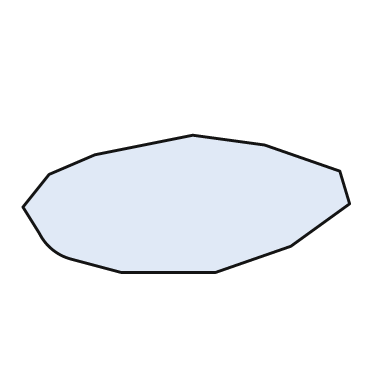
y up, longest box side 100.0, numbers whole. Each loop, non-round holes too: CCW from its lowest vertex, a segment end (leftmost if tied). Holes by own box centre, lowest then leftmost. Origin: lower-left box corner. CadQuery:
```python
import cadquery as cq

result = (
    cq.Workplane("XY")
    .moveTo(30.0, 0.0)
    .lineTo(59.0, 0.0)
    .lineTo(82.0, 8.0)
    .lineTo(100.0, 21.0)
    .lineTo(97.0, 31.0)
    .lineTo(74.0, 39.0)
    .lineTo(52.0, 42.0)
    .lineTo(22.0, 36.0)
    .lineTo(8.0, 30.0)
    .lineTo(0.0, 20.0)
    .lineTo(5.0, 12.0)
    .threePointArc((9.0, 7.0), (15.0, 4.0))
    .close()
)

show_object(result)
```